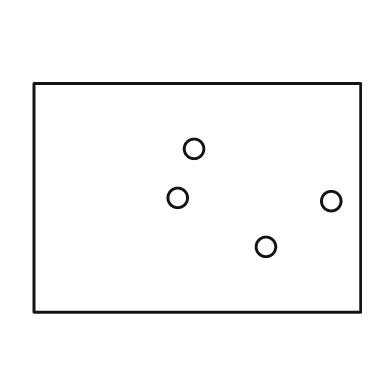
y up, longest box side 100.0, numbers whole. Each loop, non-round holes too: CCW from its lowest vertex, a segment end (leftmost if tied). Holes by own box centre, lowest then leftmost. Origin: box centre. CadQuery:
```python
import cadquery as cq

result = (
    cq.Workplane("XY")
    .moveTo(-50.0, -35.0)
    .lineTo(50.0, -35.0)
    .lineTo(50.0, 35.0)
    .lineTo(-50.0, 35.0)
    .close()
    .moveTo(21.0, -15.0)
    .circle(3.0)
    .moveTo(41.0, -1.0)
    .circle(3.0)
    .moveTo(-6.0, 0.0)
    .circle(3.0)
    .moveTo(-1.0, 15.0)
    .circle(3.0)
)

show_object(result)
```